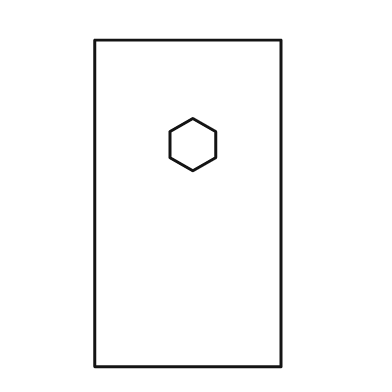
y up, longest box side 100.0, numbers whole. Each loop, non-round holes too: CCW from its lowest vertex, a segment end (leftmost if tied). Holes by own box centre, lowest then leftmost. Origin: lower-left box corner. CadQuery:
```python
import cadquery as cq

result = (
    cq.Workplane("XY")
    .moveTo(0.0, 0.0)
    .lineTo(57.0, 0.0)
    .lineTo(57.0, 100.0)
    .lineTo(0.0, 100.0)
    .close()
    .moveTo(30.0, 60.0)
    .lineTo(37.0, 64.0)
    .lineTo(37.0, 72.0)
    .lineTo(30.0, 76.0)
    .lineTo(23.0, 72.0)
    .lineTo(23.0, 64.0)
    .close()
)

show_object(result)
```